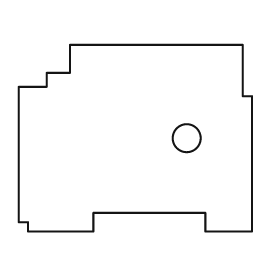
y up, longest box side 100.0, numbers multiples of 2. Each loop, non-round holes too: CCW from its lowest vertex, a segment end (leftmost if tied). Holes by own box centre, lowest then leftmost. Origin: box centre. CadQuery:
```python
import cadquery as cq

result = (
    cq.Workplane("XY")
    .moveTo(-46.0, -40.0)
    .lineTo(-18.0, -40.0)
    .lineTo(-18.0, -32.0)
    .lineTo(30.0, -32.0)
    .lineTo(30.0, -40.0)
    .lineTo(50.0, -40.0)
    .lineTo(50.0, 18.0)
    .lineTo(46.0, 18.0)
    .lineTo(46.0, 40.0)
    .lineTo(-28.0, 40.0)
    .lineTo(-28.0, 28.0)
    .lineTo(-38.0, 28.0)
    .lineTo(-38.0, 22.0)
    .lineTo(-50.0, 22.0)
    .lineTo(-50.0, -36.0)
    .lineTo(-46.0, -36.0)
    .close()
    .moveTo(22.0, 0.0)
    .circle(6.0)
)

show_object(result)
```